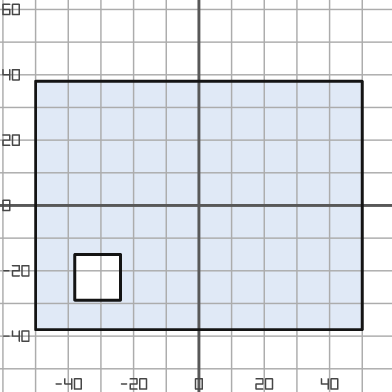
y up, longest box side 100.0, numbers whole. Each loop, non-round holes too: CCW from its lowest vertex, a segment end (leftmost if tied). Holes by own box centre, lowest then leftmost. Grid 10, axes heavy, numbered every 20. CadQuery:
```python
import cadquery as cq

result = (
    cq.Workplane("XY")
    .moveTo(-50.0, -38.0)
    .lineTo(50.0, -38.0)
    .lineTo(50.0, 38.0)
    .lineTo(-50.0, 38.0)
    .close()
    .moveTo(-38.0, -29.0)
    .lineTo(-24.0, -29.0)
    .lineTo(-24.0, -15.0)
    .lineTo(-38.0, -15.0)
    .close()
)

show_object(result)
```